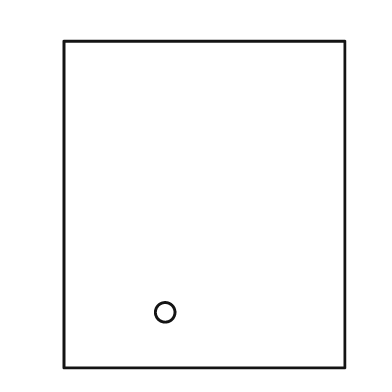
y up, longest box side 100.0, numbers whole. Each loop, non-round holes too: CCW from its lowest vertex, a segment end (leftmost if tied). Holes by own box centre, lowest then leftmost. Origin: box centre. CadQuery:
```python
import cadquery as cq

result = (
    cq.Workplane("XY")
    .moveTo(-43.0, -50.0)
    .lineTo(43.0, -50.0)
    .lineTo(43.0, 50.0)
    .lineTo(-43.0, 50.0)
    .close()
    .moveTo(-12.0, -33.0)
    .circle(3.0)
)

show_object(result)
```